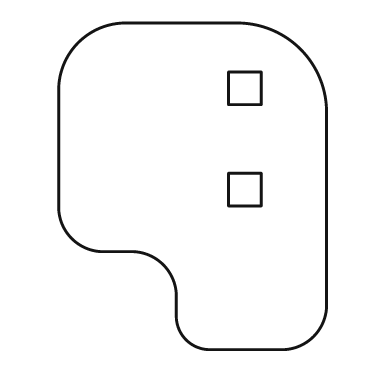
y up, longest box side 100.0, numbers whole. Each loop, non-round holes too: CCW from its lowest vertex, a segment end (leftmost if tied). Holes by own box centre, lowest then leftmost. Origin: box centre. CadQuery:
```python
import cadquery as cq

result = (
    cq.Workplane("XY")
    .moveTo(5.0, -50.0)
    .lineTo(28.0, -50.0)
    .threePointArc((37.0, -46.0), (41.0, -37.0))
    .lineTo(41.0, 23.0)
    .threePointArc((33.0, 42.0), (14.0, 50.0))
    .lineTo(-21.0, 50.0)
    .threePointArc((-35.0, 44.0), (-41.0, 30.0))
    .lineTo(-41.0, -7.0)
    .threePointArc((-37.0, -16.0), (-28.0, -20.0))
    .lineTo(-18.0, -20.0)
    .threePointArc((-9.0, -24.0), (-5.0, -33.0))
    .lineTo(-5.0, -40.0)
    .threePointArc((-2.0, -47.0), (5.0, -50.0))
    .close()
    .moveTo(11.0, -6.0)
    .lineTo(21.0, -6.0)
    .lineTo(21.0, 4.0)
    .lineTo(11.0, 4.0)
    .close()
    .moveTo(11.0, 25.0)
    .lineTo(21.0, 25.0)
    .lineTo(21.0, 35.0)
    .lineTo(11.0, 35.0)
    .close()
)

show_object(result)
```